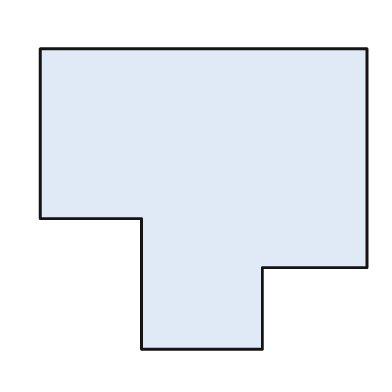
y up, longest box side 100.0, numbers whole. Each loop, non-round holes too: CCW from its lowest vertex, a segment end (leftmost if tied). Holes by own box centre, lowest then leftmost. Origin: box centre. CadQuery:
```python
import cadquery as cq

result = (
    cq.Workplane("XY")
    .moveTo(-19.0, -46.0)
    .lineTo(18.0, -46.0)
    .lineTo(18.0, -21.0)
    .lineTo(50.0, -21.0)
    .lineTo(50.0, 46.0)
    .lineTo(-50.0, 46.0)
    .lineTo(-50.0, -6.0)
    .lineTo(-19.0, -6.0)
    .close()
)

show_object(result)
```